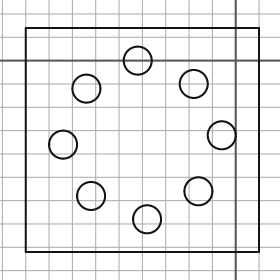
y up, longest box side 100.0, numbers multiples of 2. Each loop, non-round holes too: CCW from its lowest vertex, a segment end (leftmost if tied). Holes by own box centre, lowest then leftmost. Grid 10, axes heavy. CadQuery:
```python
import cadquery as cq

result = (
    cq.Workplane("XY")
    .moveTo(-90.0, -82.0)
    .lineTo(10.0, -82.0)
    .lineTo(10.0, 14.0)
    .lineTo(-90.0, 14.0)
    .close()
    .moveTo(-38.0, -68.0)
    .circle(6.0)
    .moveTo(-62.0, -58.0)
    .circle(6.0)
    .moveTo(-16.0, -56.0)
    .circle(6.0)
    .moveTo(-74.0, -36.0)
    .circle(6.0)
    .moveTo(-6.0, -32.0)
    .circle(6.0)
    .moveTo(-64.0, -12.0)
    .circle(6.0)
    .moveTo(-18.0, -10.0)
    .circle(6.0)
    .moveTo(-42.0, 0.0)
    .circle(6.0)
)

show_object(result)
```